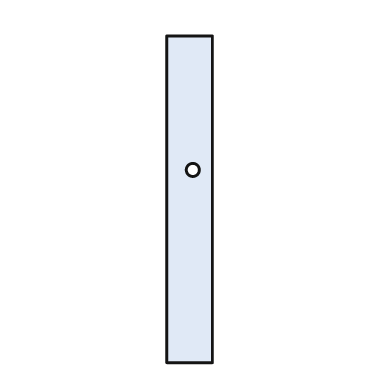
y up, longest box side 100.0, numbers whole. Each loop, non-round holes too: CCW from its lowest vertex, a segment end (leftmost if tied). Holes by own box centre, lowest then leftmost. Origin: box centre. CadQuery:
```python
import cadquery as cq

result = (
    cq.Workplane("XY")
    .moveTo(-7.0, -50.0)
    .lineTo(7.0, -50.0)
    .lineTo(7.0, 50.0)
    .lineTo(-7.0, 50.0)
    .close()
    .moveTo(1.0, 9.0)
    .circle(2.0)
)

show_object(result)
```